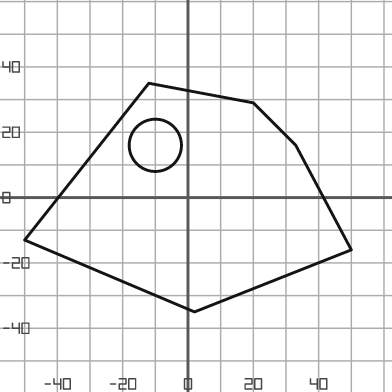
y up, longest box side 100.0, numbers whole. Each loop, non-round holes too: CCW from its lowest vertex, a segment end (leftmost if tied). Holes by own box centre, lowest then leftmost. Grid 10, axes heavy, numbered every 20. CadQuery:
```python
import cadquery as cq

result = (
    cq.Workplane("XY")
    .moveTo(2.0, -35.0)
    .lineTo(50.0, -16.0)
    .lineTo(33.0, 16.0)
    .lineTo(20.0, 29.0)
    .lineTo(-12.0, 35.0)
    .lineTo(-50.0, -13.0)
    .close()
    .moveTo(-10.0, 16.0)
    .circle(8.0)
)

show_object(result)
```